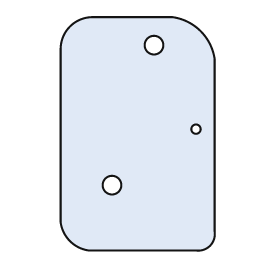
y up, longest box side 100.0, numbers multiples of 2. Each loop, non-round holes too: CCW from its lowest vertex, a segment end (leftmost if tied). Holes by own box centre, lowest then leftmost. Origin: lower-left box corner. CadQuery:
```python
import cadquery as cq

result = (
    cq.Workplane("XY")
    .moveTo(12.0, 0.0)
    .lineTo(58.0, 0.0)
    .threePointArc((64.0, 2.0), (66.0, 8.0))
    .lineTo(66.0, 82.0)
    .threePointArc((60.0, 94.0), (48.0, 100.0))
    .lineTo(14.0, 100.0)
    .threePointArc((4.0, 96.0), (0.0, 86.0))
    .lineTo(0.0, 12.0)
    .threePointArc((4.0, 4.0), (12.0, 0.0))
    .close()
    .moveTo(22.0, 28.0)
    .circle(4.0)
    .moveTo(58.0, 52.0)
    .circle(2.0)
    .moveTo(40.0, 88.0)
    .circle(4.0)
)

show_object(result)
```